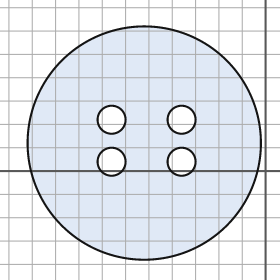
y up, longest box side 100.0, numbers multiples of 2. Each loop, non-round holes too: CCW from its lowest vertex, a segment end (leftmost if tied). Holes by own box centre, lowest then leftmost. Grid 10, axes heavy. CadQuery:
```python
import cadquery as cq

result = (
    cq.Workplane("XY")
    .moveTo(-52.0, 12.0)
    .circle(50.0)
    .moveTo(-66.0, 4.0)
    .circle(6.0)
    .moveTo(-36.0, 4.0)
    .circle(6.0)
    .moveTo(-66.0, 22.0)
    .circle(6.0)
    .moveTo(-36.0, 22.0)
    .circle(6.0)
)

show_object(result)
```